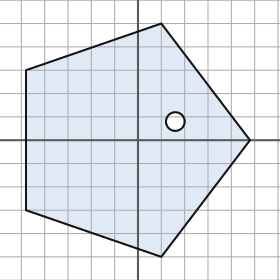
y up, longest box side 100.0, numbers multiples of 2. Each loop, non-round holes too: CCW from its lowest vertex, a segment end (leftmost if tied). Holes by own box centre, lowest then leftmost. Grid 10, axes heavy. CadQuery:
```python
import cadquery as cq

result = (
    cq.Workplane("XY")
    .moveTo(10.0, -50.0)
    .lineTo(48.0, 0.0)
    .lineTo(10.0, 50.0)
    .lineTo(-48.0, 30.0)
    .lineTo(-48.0, -30.0)
    .close()
    .moveTo(16.0, 8.0)
    .circle(4.0)
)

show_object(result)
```